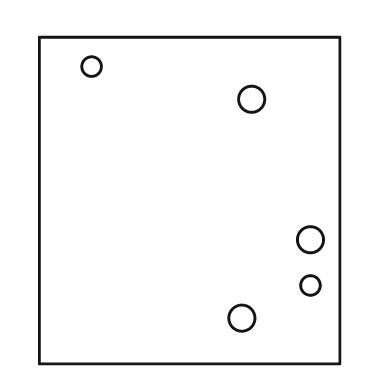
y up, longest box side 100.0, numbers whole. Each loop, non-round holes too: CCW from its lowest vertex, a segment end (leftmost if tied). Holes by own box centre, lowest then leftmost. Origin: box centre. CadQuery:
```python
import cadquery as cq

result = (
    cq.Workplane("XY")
    .moveTo(-46.0, -50.0)
    .lineTo(46.0, -50.0)
    .lineTo(46.0, 50.0)
    .lineTo(-46.0, 50.0)
    .close()
    .moveTo(16.0, -36.0)
    .circle(4.0)
    .moveTo(37.0, -26.0)
    .circle(3.0)
    .moveTo(37.0, -12.0)
    .circle(4.0)
    .moveTo(19.0, 31.0)
    .circle(4.0)
    .moveTo(-30.0, 41.0)
    .circle(3.0)
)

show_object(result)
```